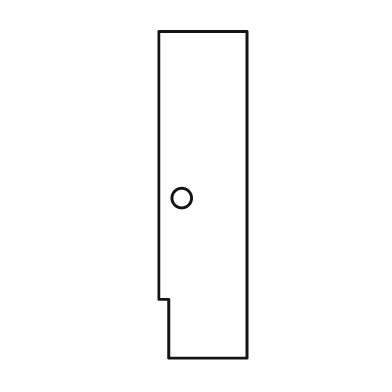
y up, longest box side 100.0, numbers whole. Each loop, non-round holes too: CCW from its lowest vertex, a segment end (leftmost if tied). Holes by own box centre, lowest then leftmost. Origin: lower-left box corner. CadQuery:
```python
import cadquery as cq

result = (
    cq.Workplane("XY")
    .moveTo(3.0, 0.0)
    .lineTo(27.0, 0.0)
    .lineTo(27.0, 100.0)
    .lineTo(0.0, 100.0)
    .lineTo(0.0, 18.0)
    .lineTo(3.0, 18.0)
    .close()
    .moveTo(7.0, 49.0)
    .circle(3.0)
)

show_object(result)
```